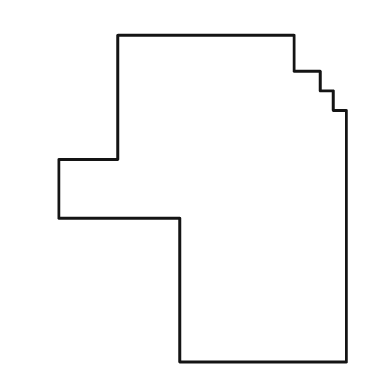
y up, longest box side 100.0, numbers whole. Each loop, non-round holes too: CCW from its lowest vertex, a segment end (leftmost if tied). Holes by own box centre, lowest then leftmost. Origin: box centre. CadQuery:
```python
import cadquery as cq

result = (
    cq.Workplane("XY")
    .moveTo(-7.0, -50.0)
    .lineTo(44.0, -50.0)
    .lineTo(44.0, 27.0)
    .lineTo(40.0, 27.0)
    .lineTo(40.0, 33.0)
    .lineTo(36.0, 33.0)
    .lineTo(36.0, 39.0)
    .lineTo(28.0, 39.0)
    .lineTo(28.0, 50.0)
    .lineTo(-26.0, 50.0)
    .lineTo(-26.0, 12.0)
    .lineTo(-44.0, 12.0)
    .lineTo(-44.0, -6.0)
    .lineTo(-7.0, -6.0)
    .close()
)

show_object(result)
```